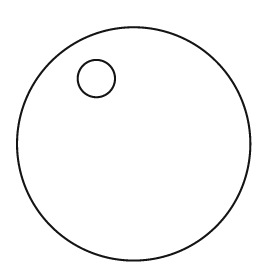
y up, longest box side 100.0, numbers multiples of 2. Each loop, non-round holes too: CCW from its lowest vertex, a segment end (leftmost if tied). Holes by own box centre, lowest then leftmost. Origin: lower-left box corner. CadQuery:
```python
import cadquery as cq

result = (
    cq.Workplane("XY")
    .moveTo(50.0, 50.0)
    .circle(50.0)
    .moveTo(34.0, 78.0)
    .circle(8.0)
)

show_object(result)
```